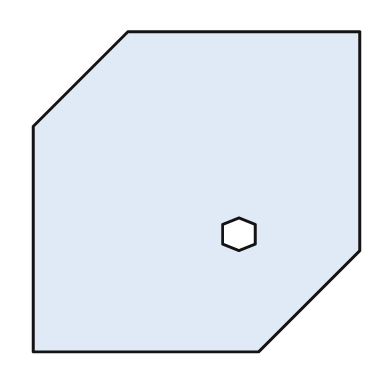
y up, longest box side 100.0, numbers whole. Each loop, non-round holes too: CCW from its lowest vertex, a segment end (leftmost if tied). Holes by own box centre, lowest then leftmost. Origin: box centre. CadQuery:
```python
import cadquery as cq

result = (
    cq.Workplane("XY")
    .moveTo(-50.0, -49.0)
    .lineTo(19.0, -49.0)
    .lineTo(50.0, -18.0)
    .lineTo(50.0, 49.0)
    .lineTo(-21.0, 49.0)
    .lineTo(-50.0, 20.0)
    .close()
    .moveTo(13.0, -18.0)
    .lineTo(18.0, -16.0)
    .lineTo(18.0, -10.0)
    .lineTo(13.0, -8.0)
    .lineTo(8.0, -10.0)
    .lineTo(8.0, -16.0)
    .close()
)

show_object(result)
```